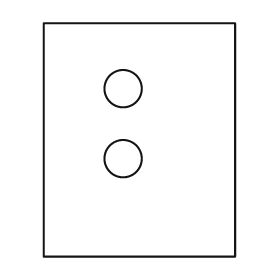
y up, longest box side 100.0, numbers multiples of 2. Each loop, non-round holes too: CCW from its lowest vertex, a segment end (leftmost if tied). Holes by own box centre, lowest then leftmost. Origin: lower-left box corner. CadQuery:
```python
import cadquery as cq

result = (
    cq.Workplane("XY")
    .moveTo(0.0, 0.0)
    .lineTo(82.0, 0.0)
    .lineTo(82.0, 100.0)
    .lineTo(0.0, 100.0)
    .close()
    .moveTo(34.0, 42.0)
    .circle(8.0)
    .moveTo(34.0, 72.0)
    .circle(8.0)
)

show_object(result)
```